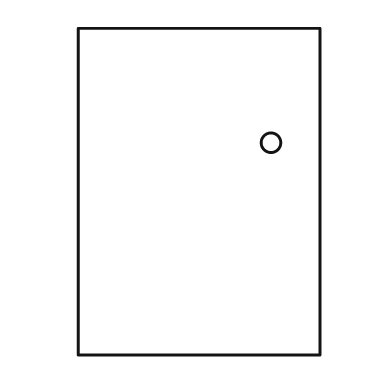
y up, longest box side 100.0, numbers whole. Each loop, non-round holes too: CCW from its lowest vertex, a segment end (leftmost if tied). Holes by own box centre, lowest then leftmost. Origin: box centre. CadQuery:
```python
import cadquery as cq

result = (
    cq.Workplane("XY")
    .moveTo(-37.0, -50.0)
    .lineTo(37.0, -50.0)
    .lineTo(37.0, 50.0)
    .lineTo(-37.0, 50.0)
    .close()
    .moveTo(22.0, 15.0)
    .circle(3.0)
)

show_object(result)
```